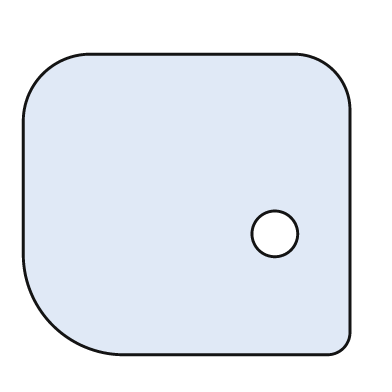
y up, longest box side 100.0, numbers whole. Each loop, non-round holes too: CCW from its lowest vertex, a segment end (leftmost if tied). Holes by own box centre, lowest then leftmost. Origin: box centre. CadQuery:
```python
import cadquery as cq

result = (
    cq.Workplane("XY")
    .moveTo(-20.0, -46.0)
    .lineTo(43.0, -46.0)
    .threePointArc((48.0, -44.0), (50.0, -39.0))
    .lineTo(50.0, 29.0)
    .threePointArc((45.0, 41.0), (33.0, 46.0))
    .lineTo(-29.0, 46.0)
    .threePointArc((-44.0, 40.0), (-50.0, 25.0))
    .lineTo(-50.0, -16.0)
    .threePointArc((-41.0, -37.0), (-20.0, -46.0))
    .close()
    .moveTo(27.0, -9.0)
    .circle(7.0)
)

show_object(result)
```